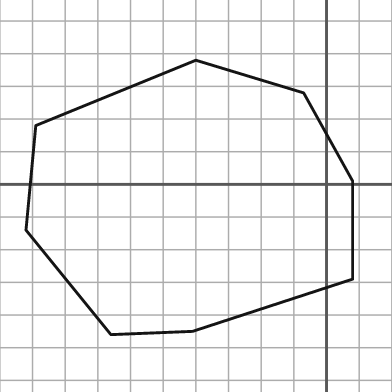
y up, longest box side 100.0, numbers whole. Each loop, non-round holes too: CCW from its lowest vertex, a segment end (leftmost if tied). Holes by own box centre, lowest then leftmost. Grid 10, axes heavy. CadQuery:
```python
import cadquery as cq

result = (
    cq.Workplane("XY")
    .moveTo(-66.0, -46.0)
    .lineTo(-41.0, -45.0)
    .lineTo(8.0, -29.0)
    .lineTo(8.0, 1.0)
    .lineTo(-7.0, 28.0)
    .lineTo(-40.0, 38.0)
    .lineTo(-89.0, 18.0)
    .lineTo(-92.0, -14.0)
    .close()
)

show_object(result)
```